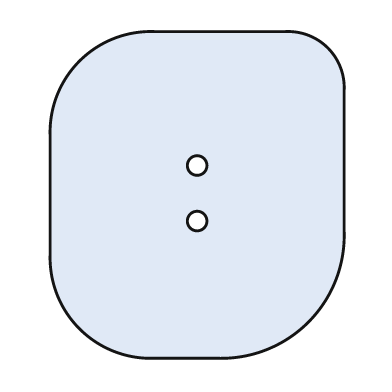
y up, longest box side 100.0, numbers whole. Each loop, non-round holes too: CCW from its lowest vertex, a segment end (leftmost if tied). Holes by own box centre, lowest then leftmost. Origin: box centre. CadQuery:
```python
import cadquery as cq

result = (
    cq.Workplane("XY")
    .moveTo(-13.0, -50.0)
    .lineTo(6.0, -50.0)
    .threePointArc((34.0, -39.0), (45.0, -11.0))
    .lineTo(45.0, 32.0)
    .threePointArc((40.0, 45.0), (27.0, 50.0))
    .lineTo(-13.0, 50.0)
    .threePointArc((-36.0, 41.0), (-45.0, 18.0))
    .lineTo(-45.0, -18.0)
    .threePointArc((-36.0, -41.0), (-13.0, -50.0))
    .close()
    .moveTo(0.0, -8.0)
    .circle(3.0)
    .moveTo(0.0, 9.0)
    .circle(3.0)
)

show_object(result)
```